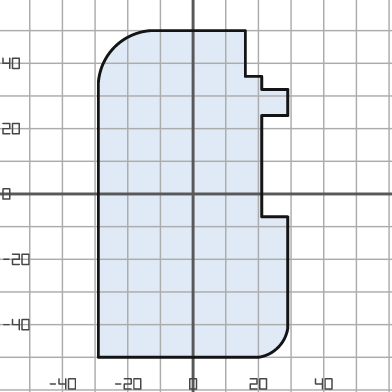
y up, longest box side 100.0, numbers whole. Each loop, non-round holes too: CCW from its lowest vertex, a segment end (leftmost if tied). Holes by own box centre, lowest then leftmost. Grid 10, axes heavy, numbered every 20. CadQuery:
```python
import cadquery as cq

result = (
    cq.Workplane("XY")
    .moveTo(-29.0, -50.0)
    .lineTo(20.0, -50.0)
    .threePointArc((26.0, -47.0), (29.0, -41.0))
    .lineTo(29.0, -7.0)
    .lineTo(21.0, -7.0)
    .lineTo(21.0, 24.0)
    .lineTo(29.0, 24.0)
    .lineTo(29.0, 32.0)
    .lineTo(21.0, 32.0)
    .lineTo(21.0, 36.0)
    .lineTo(16.0, 36.0)
    .lineTo(16.0, 50.0)
    .lineTo(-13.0, 50.0)
    .threePointArc((-24.0, 45.0), (-29.0, 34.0))
    .close()
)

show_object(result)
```